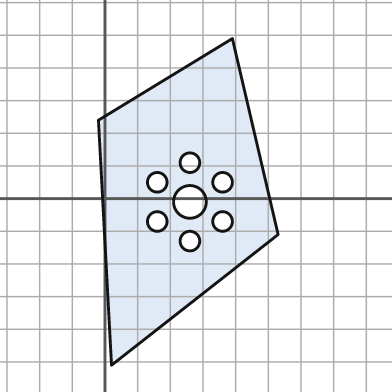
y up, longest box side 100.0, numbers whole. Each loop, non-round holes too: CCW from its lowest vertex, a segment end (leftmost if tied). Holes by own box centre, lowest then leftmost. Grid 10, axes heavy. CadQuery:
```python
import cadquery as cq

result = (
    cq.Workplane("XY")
    .moveTo(2.0, -51.0)
    .lineTo(53.0, -11.0)
    .lineTo(39.0, 49.0)
    .lineTo(-2.0, 24.0)
    .close()
    .moveTo(26.0, -13.0)
    .circle(3.0)
    .moveTo(16.0, -7.0)
    .circle(3.0)
    .moveTo(36.0, -7.0)
    .circle(3.0)
    .moveTo(26.0, -1.0)
    .circle(5.0)
    .moveTo(16.0, 5.0)
    .circle(3.0)
    .moveTo(36.0, 5.0)
    .circle(3.0)
    .moveTo(26.0, 11.0)
    .circle(3.0)
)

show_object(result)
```